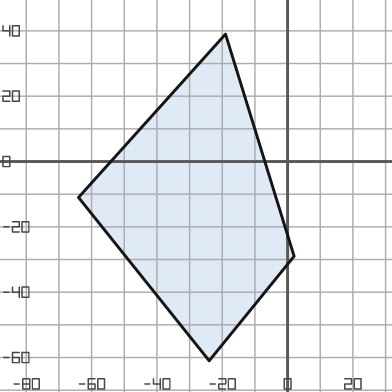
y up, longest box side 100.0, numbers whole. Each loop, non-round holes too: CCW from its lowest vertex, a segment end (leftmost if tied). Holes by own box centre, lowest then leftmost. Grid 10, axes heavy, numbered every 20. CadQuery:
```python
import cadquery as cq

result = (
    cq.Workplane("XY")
    .moveTo(-24.0, -61.0)
    .lineTo(2.0, -29.0)
    .lineTo(-19.0, 39.0)
    .lineTo(-64.0, -11.0)
    .close()
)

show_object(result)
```